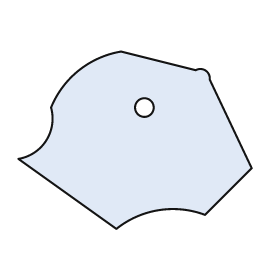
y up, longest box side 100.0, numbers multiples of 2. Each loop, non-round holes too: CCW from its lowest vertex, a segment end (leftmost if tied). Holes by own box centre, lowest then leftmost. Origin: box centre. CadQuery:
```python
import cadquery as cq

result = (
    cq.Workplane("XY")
    .moveTo(-8.0, -38.0)
    .threePointArc((10.0, -30.0), (30.0, -32.0))
    .lineTo(50.0, -12.0)
    .lineTo(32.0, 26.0)
    .threePointArc((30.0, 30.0), (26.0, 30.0))
    .lineTo(-6.0, 38.0)
    .threePointArc((-24.0, 30.0), (-36.0, 14.0))
    .threePointArc((-38.0, 0.0), (-50.0, -8.0))
    .close()
    .moveTo(4.0, 14.0)
    .circle(4.0)
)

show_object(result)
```